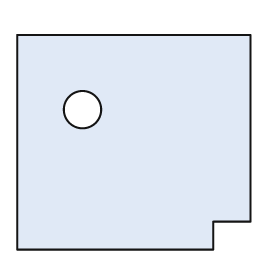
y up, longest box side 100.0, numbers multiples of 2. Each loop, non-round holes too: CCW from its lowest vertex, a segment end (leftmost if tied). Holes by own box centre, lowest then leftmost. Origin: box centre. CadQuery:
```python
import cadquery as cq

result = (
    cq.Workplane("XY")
    .moveTo(-50.0, -46.0)
    .lineTo(34.0, -46.0)
    .lineTo(34.0, -34.0)
    .lineTo(50.0, -34.0)
    .lineTo(50.0, 46.0)
    .lineTo(-50.0, 46.0)
    .close()
    .moveTo(-22.0, 14.0)
    .circle(8.0)
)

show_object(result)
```